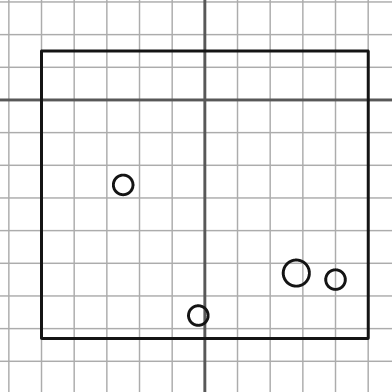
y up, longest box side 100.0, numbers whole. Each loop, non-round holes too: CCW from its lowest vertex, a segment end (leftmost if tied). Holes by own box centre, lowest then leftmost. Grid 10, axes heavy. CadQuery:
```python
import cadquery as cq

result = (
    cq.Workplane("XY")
    .moveTo(-50.0, -73.0)
    .lineTo(50.0, -73.0)
    .lineTo(50.0, 15.0)
    .lineTo(-50.0, 15.0)
    .close()
    .moveTo(-2.0, -66.0)
    .circle(3.0)
    .moveTo(40.0, -55.0)
    .circle(3.0)
    .moveTo(28.0, -53.0)
    .circle(4.0)
    .moveTo(-25.0, -26.0)
    .circle(3.0)
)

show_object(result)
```